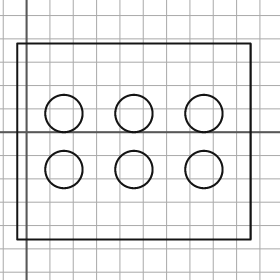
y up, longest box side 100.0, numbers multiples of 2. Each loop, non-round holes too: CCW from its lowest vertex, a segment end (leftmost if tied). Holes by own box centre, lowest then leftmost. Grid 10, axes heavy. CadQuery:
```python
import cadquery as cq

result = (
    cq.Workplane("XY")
    .moveTo(-4.0, -46.0)
    .lineTo(96.0, -46.0)
    .lineTo(96.0, 38.0)
    .lineTo(-4.0, 38.0)
    .close()
    .moveTo(16.0, -16.0)
    .circle(8.0)
    .moveTo(46.0, -16.0)
    .circle(8.0)
    .moveTo(76.0, -16.0)
    .circle(8.0)
    .moveTo(16.0, 8.0)
    .circle(8.0)
    .moveTo(46.0, 8.0)
    .circle(8.0)
    .moveTo(76.0, 8.0)
    .circle(8.0)
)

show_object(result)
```